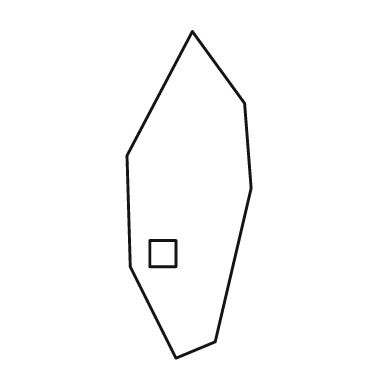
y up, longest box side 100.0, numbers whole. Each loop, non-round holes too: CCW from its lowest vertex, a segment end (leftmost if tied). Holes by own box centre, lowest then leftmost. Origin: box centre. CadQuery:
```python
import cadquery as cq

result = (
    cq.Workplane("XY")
    .moveTo(-4.0, -50.0)
    .lineTo(8.0, -45.0)
    .lineTo(19.0, 2.0)
    .lineTo(17.0, 28.0)
    .lineTo(1.0, 50.0)
    .lineTo(-19.0, 12.0)
    .lineTo(-18.0, -22.0)
    .close()
    .moveTo(-12.0, -22.0)
    .lineTo(-4.0, -22.0)
    .lineTo(-4.0, -14.0)
    .lineTo(-12.0, -14.0)
    .close()
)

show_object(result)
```